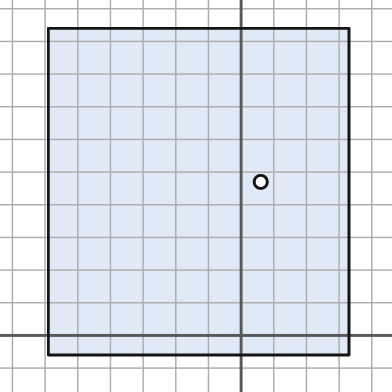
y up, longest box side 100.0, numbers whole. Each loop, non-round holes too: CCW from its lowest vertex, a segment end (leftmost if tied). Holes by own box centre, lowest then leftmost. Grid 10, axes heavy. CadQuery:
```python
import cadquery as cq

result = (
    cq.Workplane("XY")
    .moveTo(-59.0, -6.0)
    .lineTo(33.0, -6.0)
    .lineTo(33.0, 94.0)
    .lineTo(-59.0, 94.0)
    .close()
    .moveTo(6.0, 47.0)
    .circle(2.0)
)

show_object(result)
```